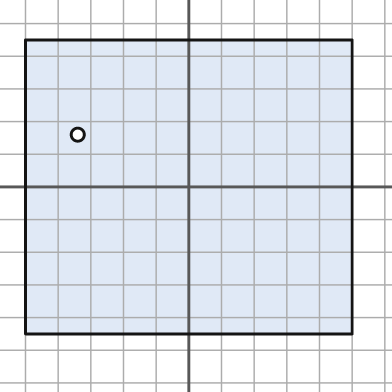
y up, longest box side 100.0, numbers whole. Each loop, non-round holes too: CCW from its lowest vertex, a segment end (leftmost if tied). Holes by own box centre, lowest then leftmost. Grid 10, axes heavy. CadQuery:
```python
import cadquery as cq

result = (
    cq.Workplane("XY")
    .moveTo(-50.0, -45.0)
    .lineTo(50.0, -45.0)
    .lineTo(50.0, 45.0)
    .lineTo(-50.0, 45.0)
    .close()
    .moveTo(-34.0, 16.0)
    .circle(2.0)
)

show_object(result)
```